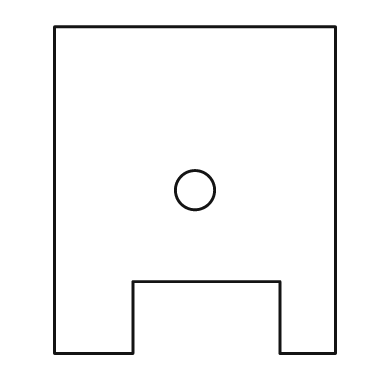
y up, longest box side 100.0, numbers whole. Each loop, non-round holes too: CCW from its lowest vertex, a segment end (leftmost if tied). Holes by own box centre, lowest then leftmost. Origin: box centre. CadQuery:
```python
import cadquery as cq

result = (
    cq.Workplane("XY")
    .moveTo(-43.0, -50.0)
    .lineTo(-19.0, -50.0)
    .lineTo(-19.0, -28.0)
    .lineTo(26.0, -28.0)
    .lineTo(26.0, -50.0)
    .lineTo(43.0, -50.0)
    .lineTo(43.0, 50.0)
    .lineTo(-43.0, 50.0)
    .close()
    .moveTo(0.0, 0.0)
    .circle(6.0)
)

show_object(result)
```